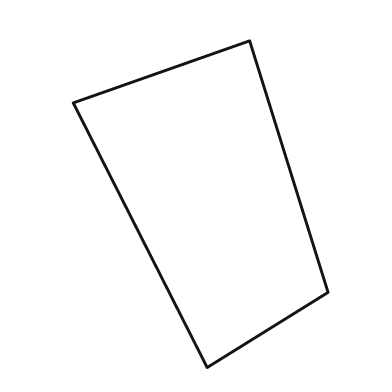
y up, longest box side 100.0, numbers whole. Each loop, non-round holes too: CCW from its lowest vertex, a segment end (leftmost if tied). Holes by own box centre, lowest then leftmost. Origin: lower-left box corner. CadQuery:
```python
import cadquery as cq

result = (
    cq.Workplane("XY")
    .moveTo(41.0, 0.0)
    .lineTo(78.0, 23.0)
    .lineTo(54.0, 100.0)
    .lineTo(0.0, 81.0)
    .close()
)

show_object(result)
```